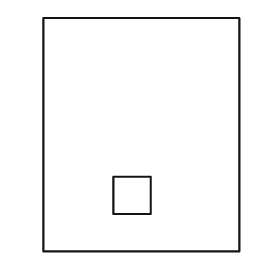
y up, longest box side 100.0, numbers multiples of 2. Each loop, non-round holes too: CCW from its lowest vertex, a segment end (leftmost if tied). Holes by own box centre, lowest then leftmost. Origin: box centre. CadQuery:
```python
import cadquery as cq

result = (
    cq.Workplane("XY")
    .moveTo(-42.0, -50.0)
    .lineTo(42.0, -50.0)
    .lineTo(42.0, 50.0)
    .lineTo(-42.0, 50.0)
    .close()
    .moveTo(-12.0, -34.0)
    .lineTo(4.0, -34.0)
    .lineTo(4.0, -18.0)
    .lineTo(-12.0, -18.0)
    .close()
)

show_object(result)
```